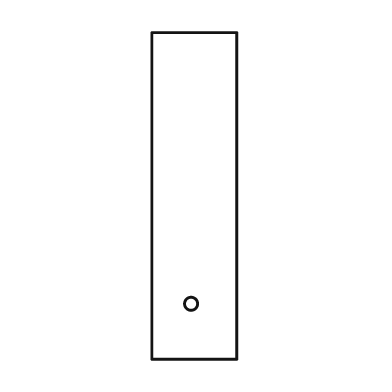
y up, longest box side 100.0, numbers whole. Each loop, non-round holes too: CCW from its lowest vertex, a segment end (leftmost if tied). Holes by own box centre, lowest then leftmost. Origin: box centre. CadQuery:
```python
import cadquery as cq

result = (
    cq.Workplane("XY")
    .moveTo(-13.0, -50.0)
    .lineTo(13.0, -50.0)
    .lineTo(13.0, 50.0)
    .lineTo(-13.0, 50.0)
    .close()
    .moveTo(-1.0, -33.0)
    .circle(2.0)
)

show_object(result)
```